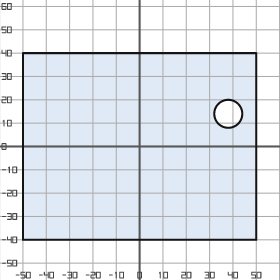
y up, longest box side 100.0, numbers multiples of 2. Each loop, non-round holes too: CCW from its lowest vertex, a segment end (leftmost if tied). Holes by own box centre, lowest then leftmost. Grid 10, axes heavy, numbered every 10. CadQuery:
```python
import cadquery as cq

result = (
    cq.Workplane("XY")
    .moveTo(-50.0, -40.0)
    .lineTo(50.0, -40.0)
    .lineTo(50.0, 40.0)
    .lineTo(-50.0, 40.0)
    .close()
    .moveTo(38.0, 14.0)
    .circle(6.0)
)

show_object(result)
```